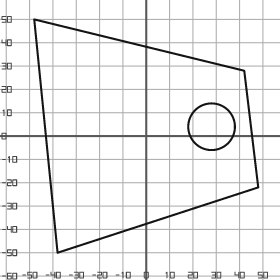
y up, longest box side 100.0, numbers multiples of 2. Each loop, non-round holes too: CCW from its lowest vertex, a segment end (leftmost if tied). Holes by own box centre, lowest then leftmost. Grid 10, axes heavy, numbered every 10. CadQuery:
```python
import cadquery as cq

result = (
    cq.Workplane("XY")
    .moveTo(-38.0, -50.0)
    .lineTo(48.0, -22.0)
    .lineTo(42.0, 28.0)
    .lineTo(-48.0, 50.0)
    .close()
    .moveTo(28.0, 4.0)
    .circle(10.0)
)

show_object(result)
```